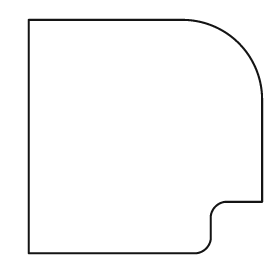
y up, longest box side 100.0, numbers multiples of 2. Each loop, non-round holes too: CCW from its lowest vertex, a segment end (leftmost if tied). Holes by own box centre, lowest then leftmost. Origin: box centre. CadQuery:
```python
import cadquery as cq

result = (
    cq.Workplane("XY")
    .moveTo(-50.0, -50.0)
    .lineTo(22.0, -50.0)
    .threePointArc((26.0, -48.0), (28.0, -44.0))
    .lineTo(28.0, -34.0)
    .threePointArc((30.0, -30.0), (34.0, -28.0))
    .lineTo(50.0, -28.0)
    .lineTo(50.0, 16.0)
    .threePointArc((40.0, 40.0), (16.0, 50.0))
    .lineTo(-50.0, 50.0)
    .close()
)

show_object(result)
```